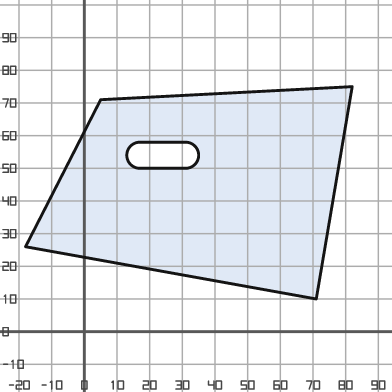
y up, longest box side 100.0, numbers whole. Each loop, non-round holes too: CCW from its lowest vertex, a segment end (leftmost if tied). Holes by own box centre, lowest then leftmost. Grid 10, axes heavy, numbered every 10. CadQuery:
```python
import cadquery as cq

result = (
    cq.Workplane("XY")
    .moveTo(71.0, 10.0)
    .lineTo(82.0, 75.0)
    .lineTo(5.0, 71.0)
    .lineTo(-18.0, 26.0)
    .close()
    .moveTo(17.0, 50.0)
    .lineTo(31.0, 50.0)
    .threePointArc((35.0, 54.0), (31.0, 58.0))
    .lineTo(17.0, 58.0)
    .threePointArc((13.0, 54.0), (17.0, 50.0))
    .close()
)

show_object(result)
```